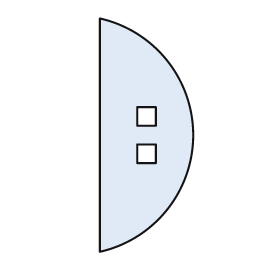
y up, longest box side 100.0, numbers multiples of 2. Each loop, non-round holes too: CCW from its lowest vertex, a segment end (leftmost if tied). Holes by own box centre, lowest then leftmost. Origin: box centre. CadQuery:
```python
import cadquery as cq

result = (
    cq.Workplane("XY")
    .moveTo(-20.0, -50.0)
    .threePointArc((20.0, 0.0), (-20.0, 50.0))
    .close()
    .moveTo(-4.0, -12.0)
    .lineTo(4.0, -12.0)
    .lineTo(4.0, -4.0)
    .lineTo(-4.0, -4.0)
    .close()
    .moveTo(-4.0, 4.0)
    .lineTo(4.0, 4.0)
    .lineTo(4.0, 12.0)
    .lineTo(-4.0, 12.0)
    .close()
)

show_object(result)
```